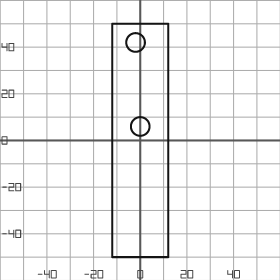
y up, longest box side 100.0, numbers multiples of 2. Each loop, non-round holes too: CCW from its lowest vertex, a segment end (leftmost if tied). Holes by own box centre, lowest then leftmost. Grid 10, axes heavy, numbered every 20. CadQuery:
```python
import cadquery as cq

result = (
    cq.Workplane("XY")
    .moveTo(-12.0, -50.0)
    .lineTo(12.0, -50.0)
    .lineTo(12.0, 50.0)
    .lineTo(-12.0, 50.0)
    .close()
    .moveTo(0.0, 6.0)
    .circle(4.0)
    .moveTo(-2.0, 42.0)
    .circle(4.0)
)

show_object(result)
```